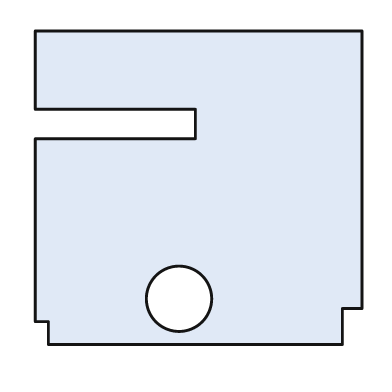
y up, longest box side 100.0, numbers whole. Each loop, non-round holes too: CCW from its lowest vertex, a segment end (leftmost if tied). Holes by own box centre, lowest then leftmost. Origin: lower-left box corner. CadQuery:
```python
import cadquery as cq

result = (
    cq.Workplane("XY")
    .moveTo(4.0, 0.0)
    .lineTo(94.0, 0.0)
    .lineTo(94.0, 11.0)
    .lineTo(100.0, 11.0)
    .lineTo(100.0, 96.0)
    .lineTo(0.0, 96.0)
    .lineTo(0.0, 72.0)
    .lineTo(49.0, 72.0)
    .lineTo(49.0, 63.0)
    .lineTo(0.0, 63.0)
    .lineTo(0.0, 7.0)
    .lineTo(4.0, 7.0)
    .close()
    .moveTo(44.0, 14.0)
    .circle(10.0)
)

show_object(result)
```